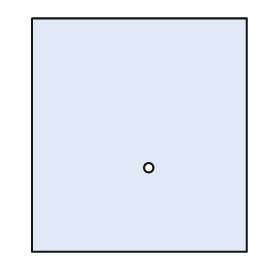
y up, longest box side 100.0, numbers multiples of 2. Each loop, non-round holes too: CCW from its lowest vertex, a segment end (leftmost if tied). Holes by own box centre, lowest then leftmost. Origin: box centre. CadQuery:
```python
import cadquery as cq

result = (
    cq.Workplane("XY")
    .moveTo(-46.0, -50.0)
    .lineTo(46.0, -50.0)
    .lineTo(46.0, 50.0)
    .lineTo(-46.0, 50.0)
    .close()
    .moveTo(4.0, -14.0)
    .circle(2.0)
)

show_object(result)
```